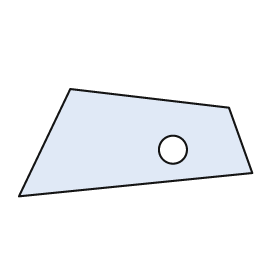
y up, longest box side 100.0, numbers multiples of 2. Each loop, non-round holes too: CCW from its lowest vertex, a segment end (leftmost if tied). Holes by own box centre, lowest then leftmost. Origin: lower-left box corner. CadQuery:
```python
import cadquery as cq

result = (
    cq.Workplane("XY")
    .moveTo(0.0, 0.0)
    .lineTo(100.0, 10.0)
    .lineTo(90.0, 38.0)
    .lineTo(22.0, 46.0)
    .close()
    .moveTo(66.0, 20.0)
    .circle(6.0)
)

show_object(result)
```